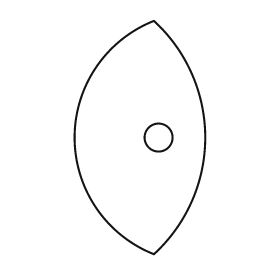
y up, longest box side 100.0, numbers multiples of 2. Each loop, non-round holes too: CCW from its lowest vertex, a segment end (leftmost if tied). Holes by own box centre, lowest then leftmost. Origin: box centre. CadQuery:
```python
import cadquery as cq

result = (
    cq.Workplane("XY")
    .moveTo(6.0, -50.0)
    .threePointArc((28.0, 0.0), (6.0, 50.0))
    .threePointArc((-28.0, 0.0), (6.0, -50.0))
    .close()
    .moveTo(8.0, 0.0)
    .circle(6.0)
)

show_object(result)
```